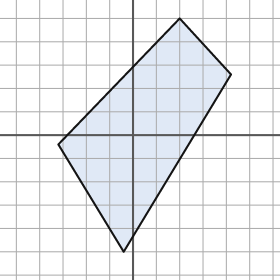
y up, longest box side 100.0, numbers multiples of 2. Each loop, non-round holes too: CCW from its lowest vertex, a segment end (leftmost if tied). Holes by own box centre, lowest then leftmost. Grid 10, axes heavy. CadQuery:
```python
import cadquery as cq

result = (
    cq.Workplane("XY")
    .moveTo(-4.0, -50.0)
    .lineTo(42.0, 26.0)
    .lineTo(20.0, 50.0)
    .lineTo(-32.0, -4.0)
    .close()
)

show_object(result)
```